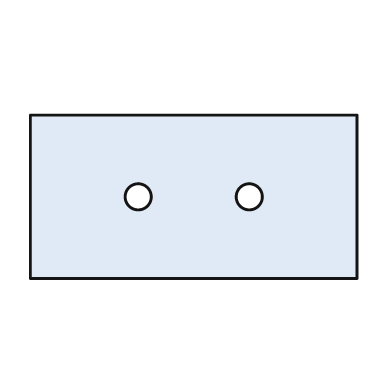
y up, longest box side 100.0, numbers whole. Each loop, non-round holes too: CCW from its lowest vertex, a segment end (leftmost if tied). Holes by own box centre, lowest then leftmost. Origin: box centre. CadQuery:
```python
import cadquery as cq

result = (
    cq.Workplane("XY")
    .moveTo(-50.0, -25.0)
    .lineTo(50.0, -25.0)
    .lineTo(50.0, 25.0)
    .lineTo(-50.0, 25.0)
    .close()
    .moveTo(-17.0, 0.0)
    .circle(4.0)
    .moveTo(17.0, 0.0)
    .circle(4.0)
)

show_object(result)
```